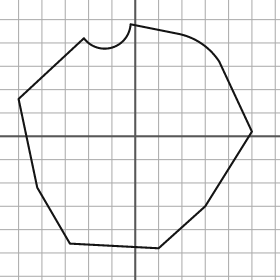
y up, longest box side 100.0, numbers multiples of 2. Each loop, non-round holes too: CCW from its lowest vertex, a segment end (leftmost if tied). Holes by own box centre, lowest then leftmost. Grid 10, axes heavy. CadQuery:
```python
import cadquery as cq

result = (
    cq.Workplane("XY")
    .moveTo(10.0, -48.0)
    .lineTo(30.0, -30.0)
    .lineTo(50.0, 2.0)
    .lineTo(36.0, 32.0)
    .threePointArc((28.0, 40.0), (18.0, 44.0))
    .lineTo(-2.0, 48.0)
    .threePointArc((-10.0, 38.0), (-22.0, 42.0))
    .lineTo(-50.0, 16.0)
    .lineTo(-42.0, -22.0)
    .lineTo(-28.0, -46.0)
    .close()
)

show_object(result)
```